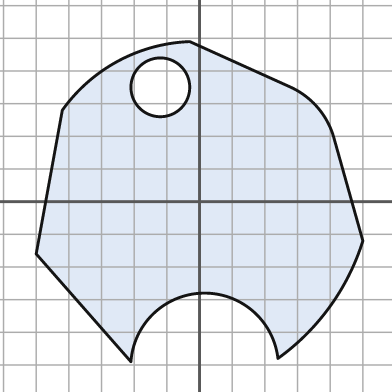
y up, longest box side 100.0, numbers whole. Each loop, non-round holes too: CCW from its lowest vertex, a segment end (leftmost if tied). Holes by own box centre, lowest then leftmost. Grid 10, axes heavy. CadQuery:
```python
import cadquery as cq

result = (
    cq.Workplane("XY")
    .moveTo(-21.0, -49.0)
    .threePointArc((1.0, -28.0), (24.0, -48.0))
    .threePointArc((40.0, -32.0), (50.0, -12.0))
    .lineTo(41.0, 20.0)
    .threePointArc((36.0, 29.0), (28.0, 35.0))
    .lineTo(-3.0, 49.0)
    .threePointArc((-25.0, 43.0), (-42.0, 28.0))
    .lineTo(-50.0, -16.0)
    .close()
    .moveTo(-12.0, 35.0)
    .circle(9.0)
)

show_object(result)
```